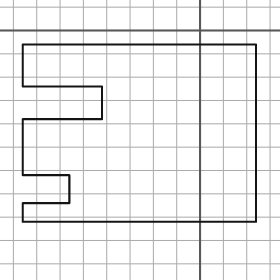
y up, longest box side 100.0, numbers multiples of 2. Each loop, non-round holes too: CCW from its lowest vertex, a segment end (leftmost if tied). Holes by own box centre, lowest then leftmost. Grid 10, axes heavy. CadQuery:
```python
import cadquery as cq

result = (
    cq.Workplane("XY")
    .moveTo(-76.0, -82.0)
    .lineTo(24.0, -82.0)
    .lineTo(24.0, -6.0)
    .lineTo(-76.0, -6.0)
    .lineTo(-76.0, -24.0)
    .lineTo(-42.0, -24.0)
    .lineTo(-42.0, -38.0)
    .lineTo(-76.0, -38.0)
    .lineTo(-76.0, -62.0)
    .lineTo(-56.0, -62.0)
    .lineTo(-56.0, -74.0)
    .lineTo(-76.0, -74.0)
    .close()
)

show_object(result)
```